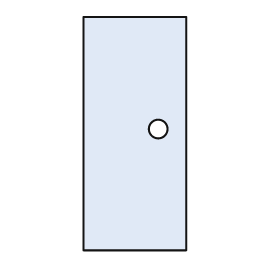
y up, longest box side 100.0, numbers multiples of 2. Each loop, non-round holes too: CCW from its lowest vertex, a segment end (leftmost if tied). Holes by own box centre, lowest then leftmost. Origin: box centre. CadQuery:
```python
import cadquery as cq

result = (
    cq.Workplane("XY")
    .moveTo(-22.0, -50.0)
    .lineTo(22.0, -50.0)
    .lineTo(22.0, 50.0)
    .lineTo(-22.0, 50.0)
    .close()
    .moveTo(10.0, 2.0)
    .circle(4.0)
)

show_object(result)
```